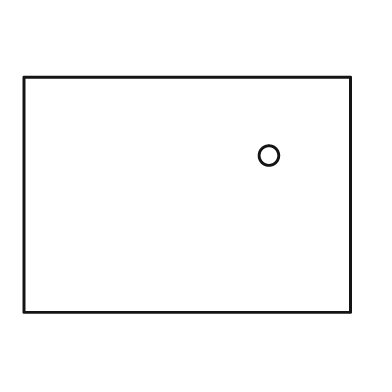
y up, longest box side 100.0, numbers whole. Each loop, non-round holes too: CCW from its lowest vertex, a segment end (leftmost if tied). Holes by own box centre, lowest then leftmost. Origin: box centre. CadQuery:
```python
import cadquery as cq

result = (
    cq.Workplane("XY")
    .moveTo(-50.0, -36.0)
    .lineTo(50.0, -36.0)
    .lineTo(50.0, 36.0)
    .lineTo(-50.0, 36.0)
    .close()
    .moveTo(25.0, 12.0)
    .circle(3.0)
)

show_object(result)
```